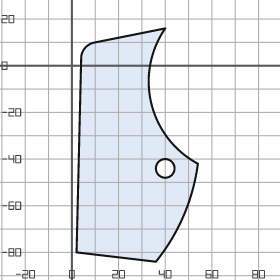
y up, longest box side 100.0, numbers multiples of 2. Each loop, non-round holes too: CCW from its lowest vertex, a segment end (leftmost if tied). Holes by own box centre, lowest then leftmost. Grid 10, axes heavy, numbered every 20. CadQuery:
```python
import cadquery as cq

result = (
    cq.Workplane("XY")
    .moveTo(36.0, -84.0)
    .threePointArc((48.0, -64.0), (54.0, -42.0))
    .threePointArc((34.0, -16.0), (40.0, 16.0))
    .lineTo(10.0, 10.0)
    .threePointArc((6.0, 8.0), (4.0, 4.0))
    .lineTo(2.0, -80.0)
    .close()
    .moveTo(40.0, -44.0)
    .circle(4.0)
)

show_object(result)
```